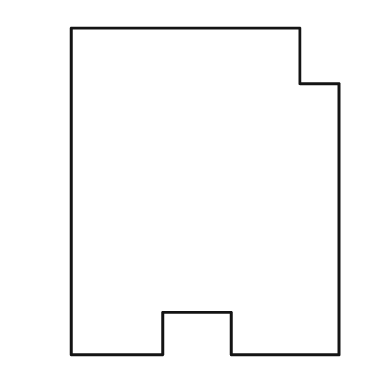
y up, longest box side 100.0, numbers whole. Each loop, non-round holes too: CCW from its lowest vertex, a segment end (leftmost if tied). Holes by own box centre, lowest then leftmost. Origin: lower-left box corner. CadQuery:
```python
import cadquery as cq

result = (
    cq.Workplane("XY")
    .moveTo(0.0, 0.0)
    .lineTo(28.0, 0.0)
    .lineTo(28.0, 13.0)
    .lineTo(49.0, 13.0)
    .lineTo(49.0, 0.0)
    .lineTo(82.0, 0.0)
    .lineTo(82.0, 83.0)
    .lineTo(70.0, 83.0)
    .lineTo(70.0, 100.0)
    .lineTo(0.0, 100.0)
    .close()
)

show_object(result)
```